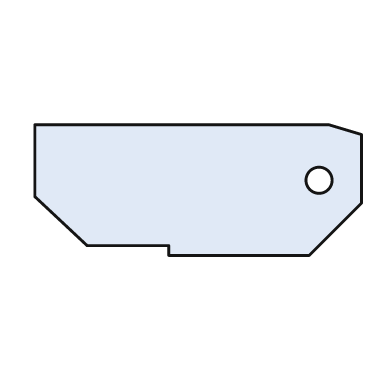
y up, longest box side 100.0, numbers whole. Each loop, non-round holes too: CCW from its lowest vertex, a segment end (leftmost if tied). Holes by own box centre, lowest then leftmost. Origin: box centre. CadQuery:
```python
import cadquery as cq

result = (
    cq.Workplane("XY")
    .moveTo(-9.0, -20.0)
    .lineTo(34.0, -20.0)
    .lineTo(50.0, -4.0)
    .lineTo(50.0, 17.0)
    .lineTo(40.0, 20.0)
    .lineTo(-50.0, 20.0)
    .lineTo(-50.0, -2.0)
    .lineTo(-34.0, -17.0)
    .lineTo(-9.0, -17.0)
    .close()
    .moveTo(37.0, 3.0)
    .circle(4.0)
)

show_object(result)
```